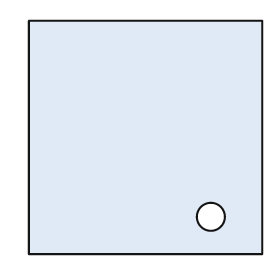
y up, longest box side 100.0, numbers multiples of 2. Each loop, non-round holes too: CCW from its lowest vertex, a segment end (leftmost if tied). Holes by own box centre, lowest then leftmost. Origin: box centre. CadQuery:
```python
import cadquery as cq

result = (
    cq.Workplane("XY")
    .moveTo(-50.0, -50.0)
    .lineTo(50.0, -50.0)
    .lineTo(50.0, 50.0)
    .lineTo(-50.0, 50.0)
    .close()
    .moveTo(28.0, -34.0)
    .circle(6.0)
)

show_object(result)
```